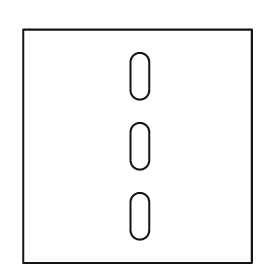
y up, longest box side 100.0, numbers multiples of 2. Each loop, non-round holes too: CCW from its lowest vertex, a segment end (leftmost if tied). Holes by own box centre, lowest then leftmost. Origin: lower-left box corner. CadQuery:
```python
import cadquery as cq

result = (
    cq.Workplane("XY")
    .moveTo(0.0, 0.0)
    .lineTo(98.0, 0.0)
    .lineTo(98.0, 100.0)
    .lineTo(0.0, 100.0)
    .close()
    .moveTo(46.0, 14.0)
    .threePointArc((50.0, 10.0), (54.0, 14.0))
    .lineTo(54.0, 26.0)
    .threePointArc((50.0, 30.0), (46.0, 26.0))
    .close()
    .moveTo(46.0, 44.0)
    .threePointArc((50.0, 40.0), (54.0, 44.0))
    .lineTo(54.0, 56.0)
    .threePointArc((50.0, 60.0), (46.0, 56.0))
    .close()
    .moveTo(46.0, 74.0)
    .threePointArc((50.0, 70.0), (54.0, 74.0))
    .lineTo(54.0, 86.0)
    .threePointArc((50.0, 90.0), (46.0, 86.0))
    .close()
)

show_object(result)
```